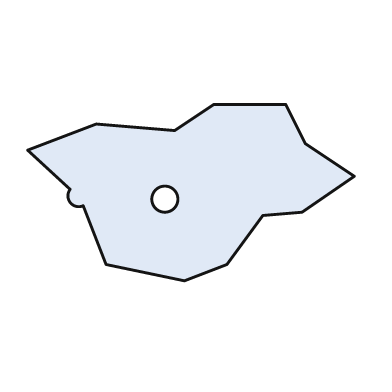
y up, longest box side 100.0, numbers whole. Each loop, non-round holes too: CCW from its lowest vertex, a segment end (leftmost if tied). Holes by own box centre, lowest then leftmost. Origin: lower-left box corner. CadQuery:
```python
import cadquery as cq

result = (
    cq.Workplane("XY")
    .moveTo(48.0, 0.0)
    .lineTo(61.0, 5.0)
    .lineTo(72.0, 20.0)
    .lineTo(84.0, 21.0)
    .lineTo(100.0, 32.0)
    .lineTo(85.0, 42.0)
    .lineTo(79.0, 54.0)
    .lineTo(57.0, 54.0)
    .lineTo(45.0, 46.0)
    .lineTo(21.0, 48.0)
    .lineTo(0.0, 40.0)
    .lineTo(13.0, 28.0)
    .threePointArc((13.0, 24.0), (17.0, 23.0))
    .lineTo(24.0, 5.0)
    .close()
    .moveTo(42.0, 25.0)
    .circle(4.0)
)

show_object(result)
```